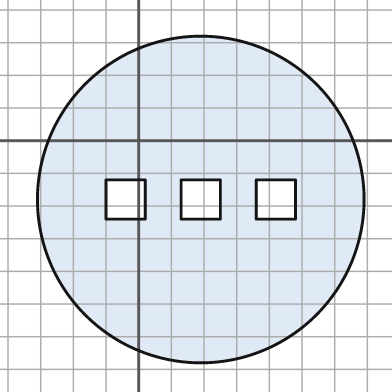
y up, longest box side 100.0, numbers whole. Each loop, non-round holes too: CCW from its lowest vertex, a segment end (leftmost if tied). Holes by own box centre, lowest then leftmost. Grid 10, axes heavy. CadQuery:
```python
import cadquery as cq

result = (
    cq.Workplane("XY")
    .moveTo(19.0, -18.0)
    .circle(50.0)
    .moveTo(-10.0, -24.0)
    .lineTo(2.0, -24.0)
    .lineTo(2.0, -12.0)
    .lineTo(-10.0, -12.0)
    .close()
    .moveTo(13.0, -24.0)
    .lineTo(25.0, -24.0)
    .lineTo(25.0, -12.0)
    .lineTo(13.0, -12.0)
    .close()
    .moveTo(36.0, -24.0)
    .lineTo(48.0, -24.0)
    .lineTo(48.0, -12.0)
    .lineTo(36.0, -12.0)
    .close()
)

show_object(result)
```